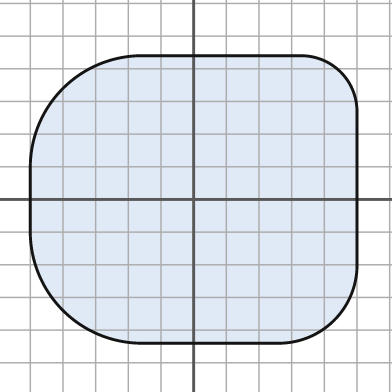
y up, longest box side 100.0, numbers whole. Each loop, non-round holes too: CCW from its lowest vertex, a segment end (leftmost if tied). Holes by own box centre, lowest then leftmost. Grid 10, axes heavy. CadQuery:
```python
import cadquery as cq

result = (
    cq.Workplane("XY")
    .moveTo(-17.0, -44.0)
    .lineTo(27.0, -44.0)
    .threePointArc((43.0, -37.0), (50.0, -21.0))
    .lineTo(50.0, 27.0)
    .threePointArc((45.0, 39.0), (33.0, 44.0))
    .lineTo(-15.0, 44.0)
    .threePointArc((-40.0, 34.0), (-50.0, 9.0))
    .lineTo(-50.0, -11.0)
    .threePointArc((-40.0, -34.0), (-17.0, -44.0))
    .close()
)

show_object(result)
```